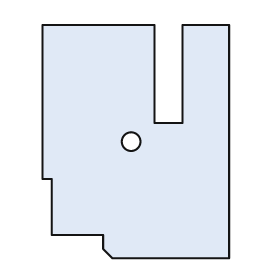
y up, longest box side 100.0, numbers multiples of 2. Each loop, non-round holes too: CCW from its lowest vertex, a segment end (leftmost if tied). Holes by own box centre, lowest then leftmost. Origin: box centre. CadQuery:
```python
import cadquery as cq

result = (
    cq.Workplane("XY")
    .moveTo(-10.0, -50.0)
    .lineTo(40.0, -50.0)
    .lineTo(40.0, 50.0)
    .lineTo(20.0, 50.0)
    .lineTo(20.0, 8.0)
    .lineTo(8.0, 8.0)
    .lineTo(8.0, 50.0)
    .lineTo(-40.0, 50.0)
    .lineTo(-40.0, -16.0)
    .lineTo(-36.0, -16.0)
    .lineTo(-36.0, -40.0)
    .lineTo(-14.0, -40.0)
    .lineTo(-14.0, -46.0)
    .close()
    .moveTo(-2.0, 0.0)
    .circle(4.0)
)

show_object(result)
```